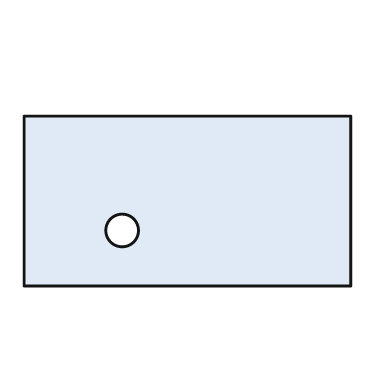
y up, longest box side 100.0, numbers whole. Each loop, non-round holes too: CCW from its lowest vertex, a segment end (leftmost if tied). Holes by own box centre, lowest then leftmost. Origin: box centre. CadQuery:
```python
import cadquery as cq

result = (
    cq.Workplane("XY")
    .moveTo(-50.0, -26.0)
    .lineTo(50.0, -26.0)
    .lineTo(50.0, 26.0)
    .lineTo(-50.0, 26.0)
    .close()
    .moveTo(-20.0, -9.0)
    .circle(5.0)
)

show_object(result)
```